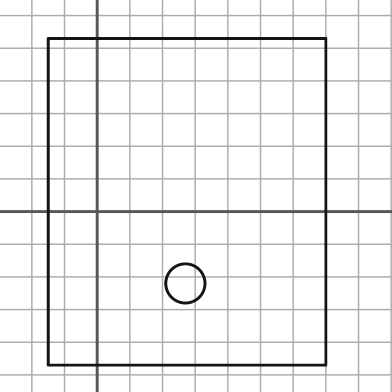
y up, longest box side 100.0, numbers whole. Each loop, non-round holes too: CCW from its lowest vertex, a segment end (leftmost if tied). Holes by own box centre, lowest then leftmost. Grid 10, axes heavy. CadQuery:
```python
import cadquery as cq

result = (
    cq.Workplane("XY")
    .moveTo(-15.0, -47.0)
    .lineTo(70.0, -47.0)
    .lineTo(70.0, 53.0)
    .lineTo(-15.0, 53.0)
    .close()
    .moveTo(27.0, -22.0)
    .circle(6.0)
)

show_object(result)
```